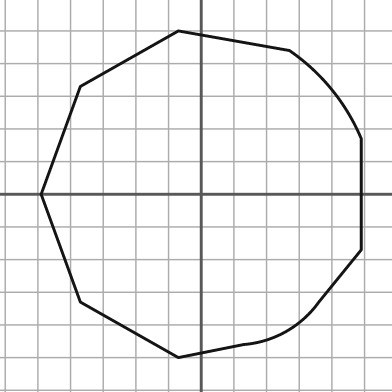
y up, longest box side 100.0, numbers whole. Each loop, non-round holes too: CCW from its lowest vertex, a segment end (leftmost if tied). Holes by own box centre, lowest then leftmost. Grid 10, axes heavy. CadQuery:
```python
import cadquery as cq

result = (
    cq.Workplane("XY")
    .moveTo(-7.0, -50.0)
    .lineTo(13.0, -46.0)
    .threePointArc((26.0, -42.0), (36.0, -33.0))
    .lineTo(49.0, -17.0)
    .lineTo(49.0, 17.0)
    .threePointArc((40.0, 32.0), (27.0, 44.0))
    .lineTo(-7.0, 50.0)
    .lineTo(-37.0, 33.0)
    .lineTo(-49.0, 0.0)
    .lineTo(-37.0, -33.0)
    .close()
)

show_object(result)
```